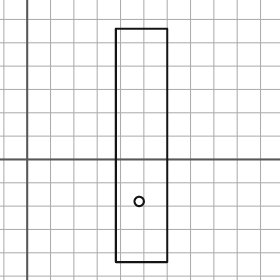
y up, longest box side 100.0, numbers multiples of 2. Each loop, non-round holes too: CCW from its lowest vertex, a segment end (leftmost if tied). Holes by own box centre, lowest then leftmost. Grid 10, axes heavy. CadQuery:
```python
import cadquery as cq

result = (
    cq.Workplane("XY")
    .moveTo(38.0, -44.0)
    .lineTo(60.0, -44.0)
    .lineTo(60.0, 56.0)
    .lineTo(38.0, 56.0)
    .close()
    .moveTo(48.0, -18.0)
    .circle(2.0)
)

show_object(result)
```